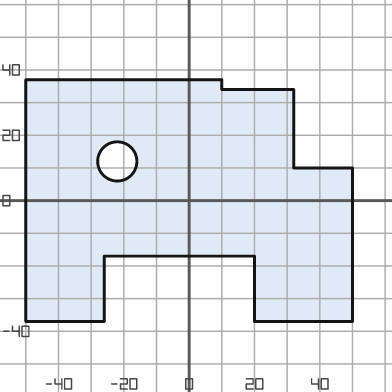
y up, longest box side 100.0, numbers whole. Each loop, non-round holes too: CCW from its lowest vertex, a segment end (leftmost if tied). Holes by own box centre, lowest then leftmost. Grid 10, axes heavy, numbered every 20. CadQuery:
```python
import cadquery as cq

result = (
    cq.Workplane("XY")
    .moveTo(-50.0, -37.0)
    .lineTo(-26.0, -37.0)
    .lineTo(-26.0, -17.0)
    .lineTo(20.0, -17.0)
    .lineTo(20.0, -37.0)
    .lineTo(50.0, -37.0)
    .lineTo(50.0, 10.0)
    .lineTo(32.0, 10.0)
    .lineTo(32.0, 34.0)
    .lineTo(10.0, 34.0)
    .lineTo(10.0, 37.0)
    .lineTo(-50.0, 37.0)
    .close()
    .moveTo(-22.0, 12.0)
    .circle(6.0)
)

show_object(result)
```